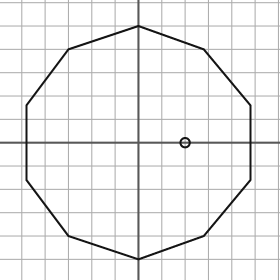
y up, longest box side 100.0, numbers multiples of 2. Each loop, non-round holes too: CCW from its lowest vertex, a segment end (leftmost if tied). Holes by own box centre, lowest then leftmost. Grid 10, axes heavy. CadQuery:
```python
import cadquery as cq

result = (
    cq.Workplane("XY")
    .moveTo(0.0, -50.0)
    .lineTo(28.0, -40.0)
    .lineTo(48.0, -16.0)
    .lineTo(48.0, 16.0)
    .lineTo(28.0, 40.0)
    .lineTo(0.0, 50.0)
    .lineTo(-30.0, 40.0)
    .lineTo(-48.0, 16.0)
    .lineTo(-48.0, -16.0)
    .lineTo(-30.0, -40.0)
    .close()
    .moveTo(20.0, 0.0)
    .circle(2.0)
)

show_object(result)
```